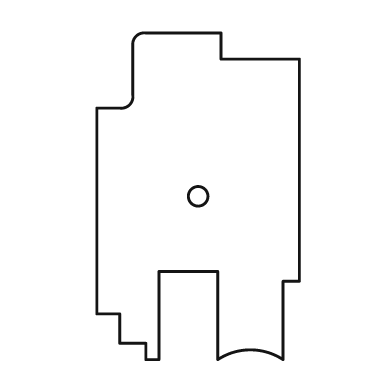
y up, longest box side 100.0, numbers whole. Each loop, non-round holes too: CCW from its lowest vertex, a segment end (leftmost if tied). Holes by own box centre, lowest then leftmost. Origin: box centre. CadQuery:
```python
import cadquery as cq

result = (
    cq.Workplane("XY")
    .moveTo(-16.0, -50.0)
    .lineTo(-12.0, -50.0)
    .lineTo(-12.0, -23.0)
    .lineTo(6.0, -23.0)
    .lineTo(6.0, -50.0)
    .threePointArc((16.0, -47.0), (26.0, -50.0))
    .lineTo(26.0, -26.0)
    .lineTo(31.0, -26.0)
    .lineTo(31.0, 42.0)
    .lineTo(7.0, 42.0)
    .lineTo(7.0, 50.0)
    .lineTo(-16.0, 50.0)
    .threePointArc((-19.0, 49.0), (-20.0, 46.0))
    .lineTo(-20.0, 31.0)
    .threePointArc((-21.0, 28.0), (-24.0, 27.0))
    .lineTo(-31.0, 27.0)
    .lineTo(-31.0, -36.0)
    .lineTo(-24.0, -36.0)
    .lineTo(-24.0, -45.0)
    .lineTo(-16.0, -45.0)
    .close()
    .moveTo(0.0, 0.0)
    .circle(3.0)
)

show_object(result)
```